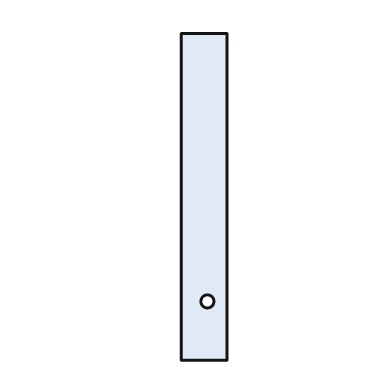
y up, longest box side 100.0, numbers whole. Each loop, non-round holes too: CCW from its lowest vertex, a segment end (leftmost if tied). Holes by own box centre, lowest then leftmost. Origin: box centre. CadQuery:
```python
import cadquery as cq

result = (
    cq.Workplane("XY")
    .moveTo(-7.0, -50.0)
    .lineTo(7.0, -50.0)
    .lineTo(7.0, 50.0)
    .lineTo(-7.0, 50.0)
    .close()
    .moveTo(1.0, -32.0)
    .circle(2.0)
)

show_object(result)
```